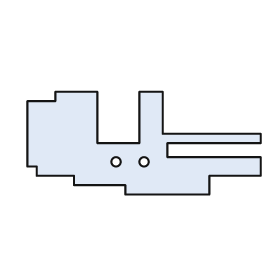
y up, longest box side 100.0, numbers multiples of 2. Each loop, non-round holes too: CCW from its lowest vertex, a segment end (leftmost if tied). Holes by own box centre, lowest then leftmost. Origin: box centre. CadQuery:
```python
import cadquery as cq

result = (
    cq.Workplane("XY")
    .moveTo(-8.0, -22.0)
    .lineTo(28.0, -22.0)
    .lineTo(28.0, -14.0)
    .lineTo(50.0, -14.0)
    .lineTo(50.0, -6.0)
    .lineTo(10.0, -6.0)
    .lineTo(10.0, 0.0)
    .lineTo(50.0, 0.0)
    .lineTo(50.0, 4.0)
    .lineTo(8.0, 4.0)
    .lineTo(8.0, 22.0)
    .lineTo(-2.0, 22.0)
    .lineTo(-2.0, 0.0)
    .lineTo(-20.0, 0.0)
    .lineTo(-20.0, 22.0)
    .lineTo(-38.0, 22.0)
    .lineTo(-38.0, 18.0)
    .lineTo(-50.0, 18.0)
    .lineTo(-50.0, -10.0)
    .lineTo(-46.0, -10.0)
    .lineTo(-46.0, -14.0)
    .lineTo(-30.0, -14.0)
    .lineTo(-30.0, -18.0)
    .lineTo(-8.0, -18.0)
    .close()
    .moveTo(-12.0, -8.0)
    .circle(2.0)
    .moveTo(0.0, -8.0)
    .circle(2.0)
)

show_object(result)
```